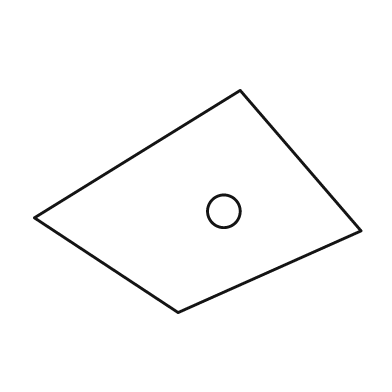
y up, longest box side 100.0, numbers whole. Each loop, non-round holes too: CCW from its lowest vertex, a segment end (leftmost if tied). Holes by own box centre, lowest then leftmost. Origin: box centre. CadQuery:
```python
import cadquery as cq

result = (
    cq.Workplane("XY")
    .moveTo(-6.0, -34.0)
    .lineTo(50.0, -9.0)
    .lineTo(13.0, 34.0)
    .lineTo(-50.0, -5.0)
    .close()
    .moveTo(8.0, -3.0)
    .circle(5.0)
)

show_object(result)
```